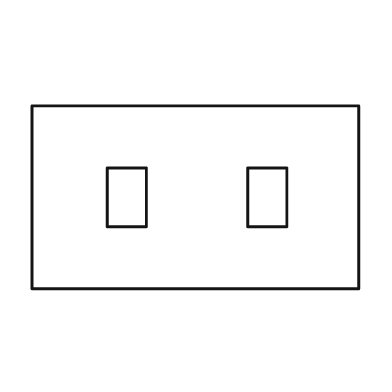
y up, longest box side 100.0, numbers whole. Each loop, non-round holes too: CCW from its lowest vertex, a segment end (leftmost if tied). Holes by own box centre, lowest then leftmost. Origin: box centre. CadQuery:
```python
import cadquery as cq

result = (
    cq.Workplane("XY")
    .moveTo(-50.0, -28.0)
    .lineTo(50.0, -28.0)
    .lineTo(50.0, 28.0)
    .lineTo(-50.0, 28.0)
    .close()
    .moveTo(-27.0, -9.0)
    .lineTo(-15.0, -9.0)
    .lineTo(-15.0, 9.0)
    .lineTo(-27.0, 9.0)
    .close()
    .moveTo(16.0, -9.0)
    .lineTo(28.0, -9.0)
    .lineTo(28.0, 9.0)
    .lineTo(16.0, 9.0)
    .close()
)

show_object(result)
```